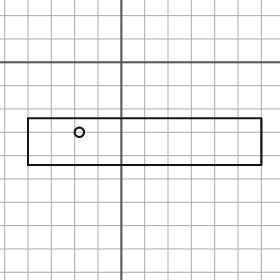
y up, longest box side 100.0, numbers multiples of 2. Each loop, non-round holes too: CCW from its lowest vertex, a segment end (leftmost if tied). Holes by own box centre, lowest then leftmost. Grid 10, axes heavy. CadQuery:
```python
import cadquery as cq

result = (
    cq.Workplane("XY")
    .moveTo(-40.0, -44.0)
    .lineTo(60.0, -44.0)
    .lineTo(60.0, -24.0)
    .lineTo(-40.0, -24.0)
    .close()
    .moveTo(-18.0, -30.0)
    .circle(2.0)
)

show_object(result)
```